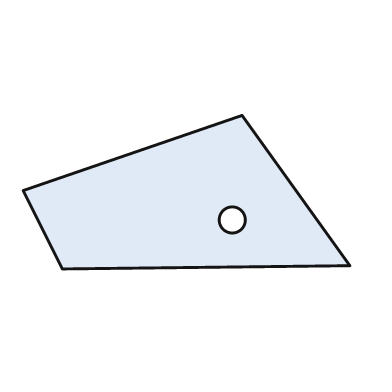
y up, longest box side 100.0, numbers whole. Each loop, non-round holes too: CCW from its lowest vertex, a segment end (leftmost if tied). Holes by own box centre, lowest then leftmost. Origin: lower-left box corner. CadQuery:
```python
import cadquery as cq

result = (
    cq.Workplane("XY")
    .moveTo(12.0, 0.0)
    .lineTo(100.0, 1.0)
    .lineTo(67.0, 47.0)
    .lineTo(0.0, 24.0)
    .close()
    .moveTo(64.0, 15.0)
    .circle(4.0)
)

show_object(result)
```